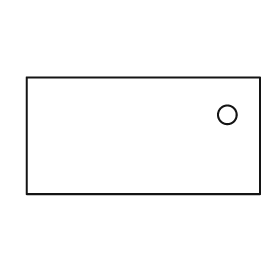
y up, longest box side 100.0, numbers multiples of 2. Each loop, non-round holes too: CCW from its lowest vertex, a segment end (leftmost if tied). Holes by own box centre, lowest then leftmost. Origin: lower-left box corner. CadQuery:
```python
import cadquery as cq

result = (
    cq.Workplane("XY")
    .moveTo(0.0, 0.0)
    .lineTo(100.0, 0.0)
    .lineTo(100.0, 50.0)
    .lineTo(0.0, 50.0)
    .close()
    .moveTo(86.0, 34.0)
    .circle(4.0)
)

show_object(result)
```